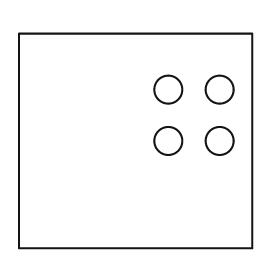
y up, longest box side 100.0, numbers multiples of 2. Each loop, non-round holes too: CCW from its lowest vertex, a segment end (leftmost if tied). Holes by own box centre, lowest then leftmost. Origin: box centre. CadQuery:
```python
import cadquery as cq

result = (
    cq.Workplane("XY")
    .moveTo(-50.0, -46.0)
    .lineTo(50.0, -46.0)
    .lineTo(50.0, 46.0)
    .lineTo(-50.0, 46.0)
    .close()
    .moveTo(14.0, 0.0)
    .circle(6.0)
    .moveTo(36.0, 0.0)
    .circle(6.0)
    .moveTo(14.0, 22.0)
    .circle(6.0)
    .moveTo(36.0, 22.0)
    .circle(6.0)
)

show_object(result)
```